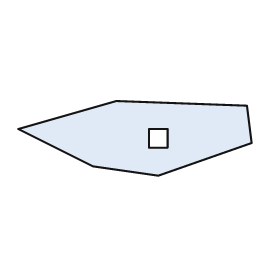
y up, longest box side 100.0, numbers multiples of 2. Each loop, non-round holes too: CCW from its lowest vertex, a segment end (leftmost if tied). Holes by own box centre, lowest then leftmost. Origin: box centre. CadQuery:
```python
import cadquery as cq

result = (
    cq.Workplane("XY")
    .moveTo(10.0, -16.0)
    .lineTo(50.0, -2.0)
    .lineTo(48.0, 14.0)
    .lineTo(-8.0, 16.0)
    .lineTo(-50.0, 4.0)
    .lineTo(-18.0, -12.0)
    .close()
    .moveTo(6.0, -4.0)
    .lineTo(14.0, -4.0)
    .lineTo(14.0, 4.0)
    .lineTo(6.0, 4.0)
    .close()
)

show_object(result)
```